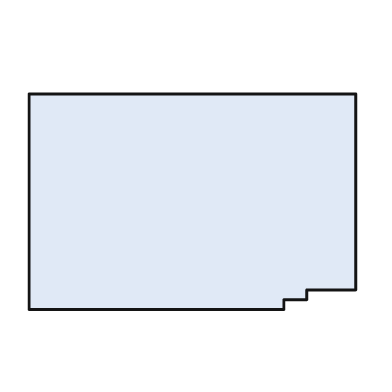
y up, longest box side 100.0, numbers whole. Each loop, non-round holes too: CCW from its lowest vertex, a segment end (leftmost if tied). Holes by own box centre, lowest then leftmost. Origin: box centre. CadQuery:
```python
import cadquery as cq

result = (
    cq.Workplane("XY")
    .moveTo(-50.0, -33.0)
    .lineTo(28.0, -33.0)
    .lineTo(28.0, -30.0)
    .lineTo(35.0, -30.0)
    .lineTo(35.0, -27.0)
    .lineTo(50.0, -27.0)
    .lineTo(50.0, 33.0)
    .lineTo(-50.0, 33.0)
    .close()
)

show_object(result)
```